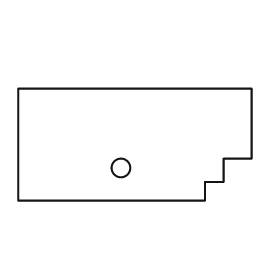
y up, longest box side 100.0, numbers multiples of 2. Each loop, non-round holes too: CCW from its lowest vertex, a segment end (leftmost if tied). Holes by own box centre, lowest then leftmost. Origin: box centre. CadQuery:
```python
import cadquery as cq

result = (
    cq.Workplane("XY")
    .moveTo(-50.0, -24.0)
    .lineTo(30.0, -24.0)
    .lineTo(30.0, -16.0)
    .lineTo(38.0, -16.0)
    .lineTo(38.0, -6.0)
    .lineTo(50.0, -6.0)
    .lineTo(50.0, 24.0)
    .lineTo(-50.0, 24.0)
    .close()
    .moveTo(-6.0, -10.0)
    .circle(4.0)
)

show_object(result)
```